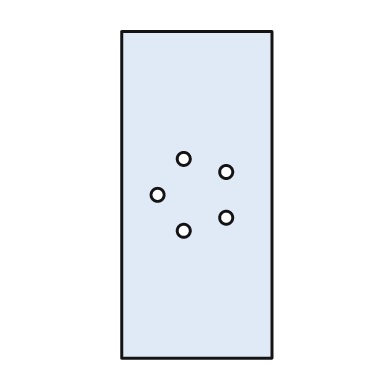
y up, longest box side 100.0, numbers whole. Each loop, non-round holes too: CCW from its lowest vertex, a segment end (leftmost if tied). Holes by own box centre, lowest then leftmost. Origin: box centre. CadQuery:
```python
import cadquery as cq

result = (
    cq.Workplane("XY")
    .moveTo(-23.0, -50.0)
    .lineTo(23.0, -50.0)
    .lineTo(23.0, 50.0)
    .lineTo(-23.0, 50.0)
    .close()
    .moveTo(-4.0, -11.0)
    .circle(2.0)
    .moveTo(9.0, -7.0)
    .circle(2.0)
    .moveTo(-12.0, 0.0)
    .circle(2.0)
    .moveTo(9.0, 7.0)
    .circle(2.0)
    .moveTo(-4.0, 11.0)
    .circle(2.0)
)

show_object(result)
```